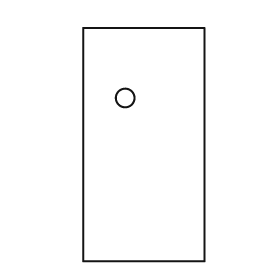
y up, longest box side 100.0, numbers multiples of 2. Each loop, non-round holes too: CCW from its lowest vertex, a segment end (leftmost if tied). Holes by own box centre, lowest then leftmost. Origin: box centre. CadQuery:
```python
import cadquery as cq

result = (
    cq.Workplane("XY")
    .moveTo(-26.0, -50.0)
    .lineTo(26.0, -50.0)
    .lineTo(26.0, 50.0)
    .lineTo(-26.0, 50.0)
    .close()
    .moveTo(-8.0, 20.0)
    .circle(4.0)
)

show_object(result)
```